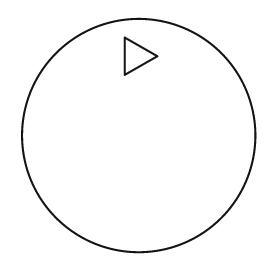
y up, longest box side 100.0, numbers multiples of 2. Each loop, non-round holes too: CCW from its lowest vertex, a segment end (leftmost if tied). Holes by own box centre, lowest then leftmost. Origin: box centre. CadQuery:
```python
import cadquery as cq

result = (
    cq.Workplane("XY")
    .moveTo(0.0, 0.0)
    .circle(50.0)
    .moveTo(-6.0, 26.0)
    .lineTo(8.0, 34.0)
    .lineTo(-6.0, 42.0)
    .close()
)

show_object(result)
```